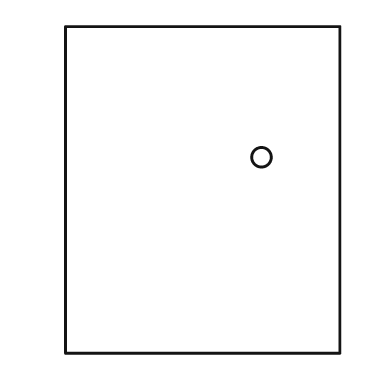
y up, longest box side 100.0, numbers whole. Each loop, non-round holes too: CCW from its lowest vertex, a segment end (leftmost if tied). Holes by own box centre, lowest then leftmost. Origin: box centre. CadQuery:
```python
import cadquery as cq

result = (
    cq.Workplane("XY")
    .moveTo(-42.0, -50.0)
    .lineTo(42.0, -50.0)
    .lineTo(42.0, 50.0)
    .lineTo(-42.0, 50.0)
    .close()
    .moveTo(18.0, 10.0)
    .circle(3.0)
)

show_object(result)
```